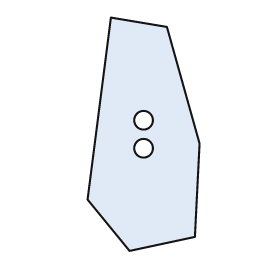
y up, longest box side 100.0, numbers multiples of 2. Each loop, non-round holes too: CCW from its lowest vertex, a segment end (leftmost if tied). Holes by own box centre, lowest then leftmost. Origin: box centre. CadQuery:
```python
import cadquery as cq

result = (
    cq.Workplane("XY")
    .moveTo(-6.0, -50.0)
    .lineTo(22.0, -44.0)
    .lineTo(24.0, -4.0)
    .lineTo(10.0, 46.0)
    .lineTo(-14.0, 50.0)
    .lineTo(-24.0, -28.0)
    .close()
    .moveTo(0.0, -6.0)
    .circle(4.0)
    .moveTo(0.0, 6.0)
    .circle(4.0)
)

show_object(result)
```